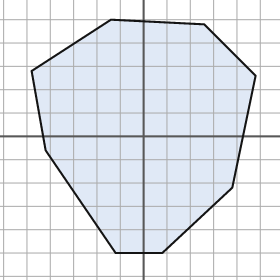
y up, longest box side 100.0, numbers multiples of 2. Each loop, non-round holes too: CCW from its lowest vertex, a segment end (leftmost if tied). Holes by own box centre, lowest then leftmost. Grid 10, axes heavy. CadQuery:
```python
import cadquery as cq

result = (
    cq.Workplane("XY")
    .moveTo(-12.0, -50.0)
    .lineTo(8.0, -50.0)
    .lineTo(38.0, -22.0)
    .lineTo(48.0, 26.0)
    .lineTo(26.0, 48.0)
    .lineTo(-14.0, 50.0)
    .lineTo(-48.0, 28.0)
    .lineTo(-42.0, -6.0)
    .close()
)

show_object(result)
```